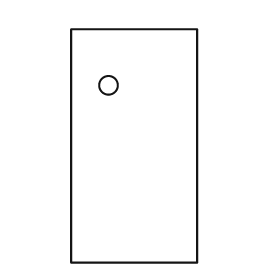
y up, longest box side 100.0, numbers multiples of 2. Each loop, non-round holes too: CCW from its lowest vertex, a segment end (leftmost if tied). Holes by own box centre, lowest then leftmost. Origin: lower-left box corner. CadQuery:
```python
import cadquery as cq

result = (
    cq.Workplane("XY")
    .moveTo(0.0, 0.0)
    .lineTo(54.0, 0.0)
    .lineTo(54.0, 100.0)
    .lineTo(0.0, 100.0)
    .close()
    .moveTo(16.0, 76.0)
    .circle(4.0)
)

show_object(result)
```